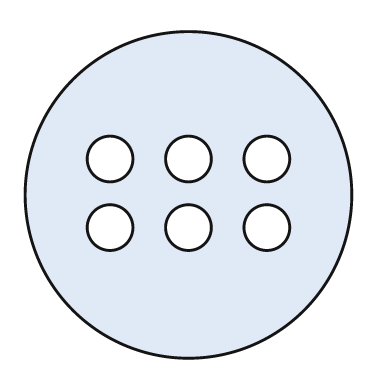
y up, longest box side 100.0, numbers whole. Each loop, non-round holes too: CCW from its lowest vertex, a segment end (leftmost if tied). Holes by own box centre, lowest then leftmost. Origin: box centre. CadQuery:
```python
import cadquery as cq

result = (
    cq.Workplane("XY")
    .moveTo(0.0, 0.0)
    .circle(50.0)
    .moveTo(-24.0, -10.0)
    .circle(7.0)
    .moveTo(0.0, -10.0)
    .circle(7.0)
    .moveTo(24.0, -10.0)
    .circle(7.0)
    .moveTo(-24.0, 11.0)
    .circle(7.0)
    .moveTo(0.0, 11.0)
    .circle(7.0)
    .moveTo(24.0, 11.0)
    .circle(7.0)
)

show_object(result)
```